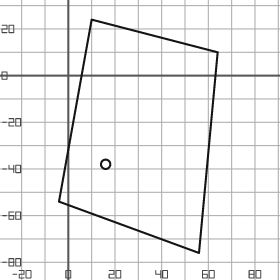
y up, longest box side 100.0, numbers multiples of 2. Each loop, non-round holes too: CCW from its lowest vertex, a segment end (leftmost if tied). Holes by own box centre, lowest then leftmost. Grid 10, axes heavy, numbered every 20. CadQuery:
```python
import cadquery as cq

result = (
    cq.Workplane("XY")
    .moveTo(56.0, -76.0)
    .lineTo(64.0, 10.0)
    .lineTo(10.0, 24.0)
    .lineTo(-4.0, -54.0)
    .close()
    .moveTo(16.0, -38.0)
    .circle(2.0)
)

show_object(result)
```